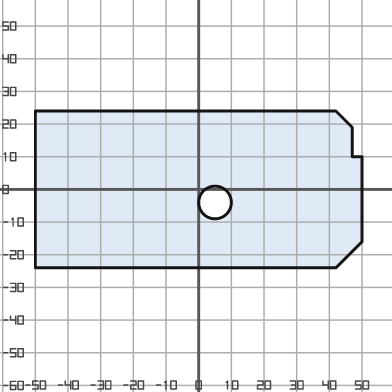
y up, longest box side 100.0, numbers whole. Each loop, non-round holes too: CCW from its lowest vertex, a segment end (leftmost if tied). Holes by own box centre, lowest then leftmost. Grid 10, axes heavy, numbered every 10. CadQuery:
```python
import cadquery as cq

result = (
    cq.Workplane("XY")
    .moveTo(-50.0, -24.0)
    .lineTo(42.0, -24.0)
    .lineTo(50.0, -16.0)
    .lineTo(50.0, 10.0)
    .lineTo(47.0, 10.0)
    .lineTo(47.0, 19.0)
    .lineTo(42.0, 24.0)
    .lineTo(-50.0, 24.0)
    .close()
    .moveTo(5.0, -4.0)
    .circle(5.0)
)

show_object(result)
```